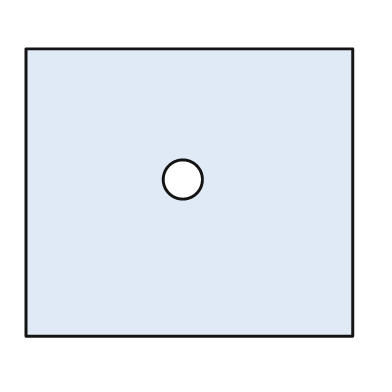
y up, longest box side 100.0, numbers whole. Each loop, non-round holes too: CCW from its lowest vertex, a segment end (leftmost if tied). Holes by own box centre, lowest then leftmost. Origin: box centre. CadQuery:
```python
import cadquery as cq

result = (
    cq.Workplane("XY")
    .moveTo(-50.0, -44.0)
    .lineTo(50.0, -44.0)
    .lineTo(50.0, 44.0)
    .lineTo(-50.0, 44.0)
    .close()
    .moveTo(-2.0, 4.0)
    .circle(6.0)
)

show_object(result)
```